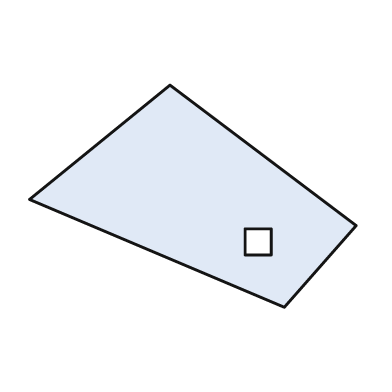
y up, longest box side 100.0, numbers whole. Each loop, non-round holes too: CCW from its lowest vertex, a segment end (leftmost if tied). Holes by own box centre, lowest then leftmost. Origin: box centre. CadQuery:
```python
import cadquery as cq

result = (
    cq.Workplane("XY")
    .moveTo(28.0, -34.0)
    .lineTo(50.0, -9.0)
    .lineTo(-7.0, 34.0)
    .lineTo(-50.0, -1.0)
    .close()
    .moveTo(16.0, -18.0)
    .lineTo(24.0, -18.0)
    .lineTo(24.0, -10.0)
    .lineTo(16.0, -10.0)
    .close()
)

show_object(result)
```